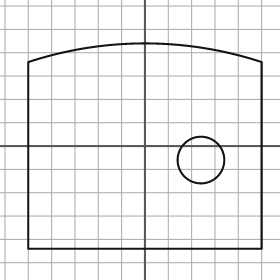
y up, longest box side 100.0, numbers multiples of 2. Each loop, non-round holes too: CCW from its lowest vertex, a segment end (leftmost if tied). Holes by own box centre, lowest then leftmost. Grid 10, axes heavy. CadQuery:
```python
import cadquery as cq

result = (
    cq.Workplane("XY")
    .moveTo(-50.0, -44.0)
    .lineTo(50.0, -44.0)
    .lineTo(50.0, 36.0)
    .threePointArc((0.0, 44.0), (-50.0, 36.0))
    .close()
    .moveTo(24.0, -6.0)
    .circle(10.0)
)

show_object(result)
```